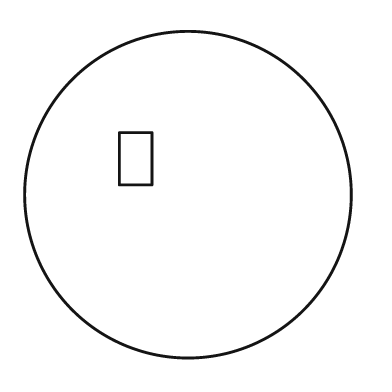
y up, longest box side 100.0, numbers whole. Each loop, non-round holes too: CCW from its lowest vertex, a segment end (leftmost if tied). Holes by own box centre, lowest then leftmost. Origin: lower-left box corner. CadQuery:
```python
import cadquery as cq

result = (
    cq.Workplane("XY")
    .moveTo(50.0, 50.0)
    .circle(50.0)
    .moveTo(29.0, 53.0)
    .lineTo(39.0, 53.0)
    .lineTo(39.0, 69.0)
    .lineTo(29.0, 69.0)
    .close()
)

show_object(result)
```